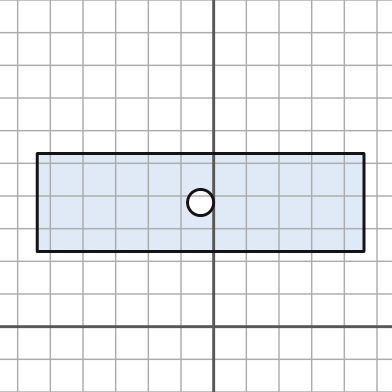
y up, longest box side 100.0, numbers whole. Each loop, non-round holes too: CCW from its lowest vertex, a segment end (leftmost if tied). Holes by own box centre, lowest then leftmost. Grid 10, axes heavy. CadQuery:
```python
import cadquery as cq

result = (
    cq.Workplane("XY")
    .moveTo(-54.0, 23.0)
    .lineTo(46.0, 23.0)
    .lineTo(46.0, 53.0)
    .lineTo(-54.0, 53.0)
    .close()
    .moveTo(-4.0, 38.0)
    .circle(4.0)
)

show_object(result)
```